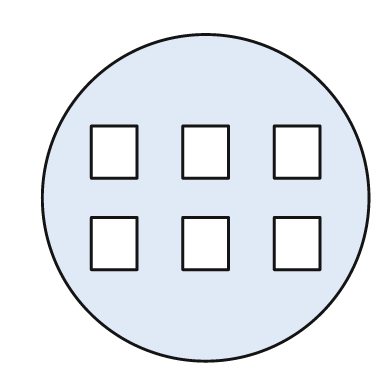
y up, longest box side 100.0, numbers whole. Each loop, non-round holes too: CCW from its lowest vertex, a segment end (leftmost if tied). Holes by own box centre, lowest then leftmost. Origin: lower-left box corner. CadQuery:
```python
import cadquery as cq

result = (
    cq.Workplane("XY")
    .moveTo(50.0, 50.0)
    .circle(50.0)
    .moveTo(15.0, 28.0)
    .lineTo(29.0, 28.0)
    .lineTo(29.0, 44.0)
    .lineTo(15.0, 44.0)
    .close()
    .moveTo(43.0, 28.0)
    .lineTo(57.0, 28.0)
    .lineTo(57.0, 44.0)
    .lineTo(43.0, 44.0)
    .close()
    .moveTo(71.0, 28.0)
    .lineTo(85.0, 28.0)
    .lineTo(85.0, 44.0)
    .lineTo(71.0, 44.0)
    .close()
    .moveTo(15.0, 56.0)
    .lineTo(29.0, 56.0)
    .lineTo(29.0, 72.0)
    .lineTo(15.0, 72.0)
    .close()
    .moveTo(43.0, 56.0)
    .lineTo(57.0, 56.0)
    .lineTo(57.0, 72.0)
    .lineTo(43.0, 72.0)
    .close()
    .moveTo(71.0, 56.0)
    .lineTo(85.0, 56.0)
    .lineTo(85.0, 72.0)
    .lineTo(71.0, 72.0)
    .close()
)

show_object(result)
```